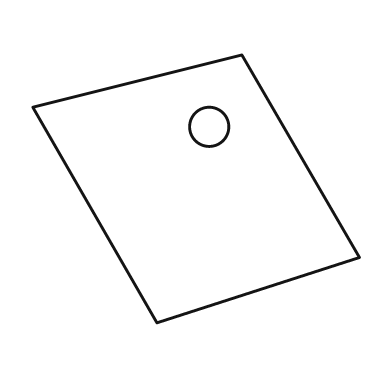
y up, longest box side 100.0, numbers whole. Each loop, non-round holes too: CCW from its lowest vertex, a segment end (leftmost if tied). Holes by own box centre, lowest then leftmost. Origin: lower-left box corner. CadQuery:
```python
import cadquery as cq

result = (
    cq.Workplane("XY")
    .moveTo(38.0, 0.0)
    .lineTo(100.0, 20.0)
    .lineTo(64.0, 82.0)
    .lineTo(0.0, 66.0)
    .close()
    .moveTo(54.0, 60.0)
    .circle(6.0)
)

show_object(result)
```